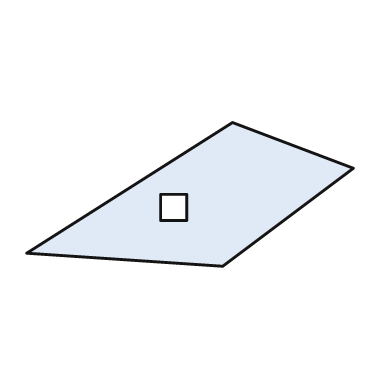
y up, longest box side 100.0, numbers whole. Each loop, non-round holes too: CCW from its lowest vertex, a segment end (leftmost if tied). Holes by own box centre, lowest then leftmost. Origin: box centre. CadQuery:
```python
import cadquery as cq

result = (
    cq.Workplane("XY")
    .moveTo(10.0, -22.0)
    .lineTo(50.0, 8.0)
    .lineTo(13.0, 22.0)
    .lineTo(-50.0, -18.0)
    .close()
    .moveTo(-9.0, -8.0)
    .lineTo(-1.0, -8.0)
    .lineTo(-1.0, 0.0)
    .lineTo(-9.0, 0.0)
    .close()
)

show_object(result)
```